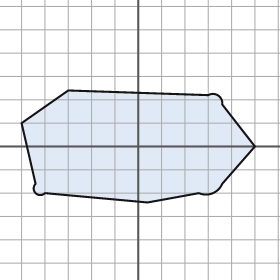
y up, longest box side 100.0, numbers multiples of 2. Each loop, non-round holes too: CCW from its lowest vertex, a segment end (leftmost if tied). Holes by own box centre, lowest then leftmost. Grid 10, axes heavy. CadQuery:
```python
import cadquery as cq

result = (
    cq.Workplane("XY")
    .moveTo(4.0, -24.0)
    .lineTo(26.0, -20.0)
    .threePointArc((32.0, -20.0), (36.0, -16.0))
    .lineTo(50.0, 0.0)
    .lineTo(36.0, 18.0)
    .threePointArc((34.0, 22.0), (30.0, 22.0))
    .lineTo(-30.0, 24.0)
    .lineTo(-50.0, 10.0)
    .lineTo(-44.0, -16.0)
    .threePointArc((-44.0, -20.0), (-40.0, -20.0))
    .close()
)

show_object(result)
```